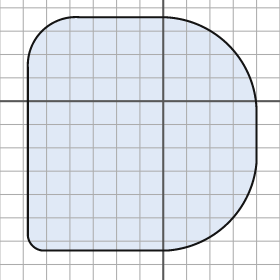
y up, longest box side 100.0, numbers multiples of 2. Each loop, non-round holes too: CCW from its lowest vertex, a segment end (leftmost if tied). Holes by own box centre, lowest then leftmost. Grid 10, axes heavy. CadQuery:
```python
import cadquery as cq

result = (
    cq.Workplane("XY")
    .moveTo(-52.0, -64.0)
    .lineTo(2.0, -64.0)
    .threePointArc((28.0, -52.0), (40.0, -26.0))
    .lineTo(40.0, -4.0)
    .threePointArc((28.0, 24.0), (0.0, 36.0))
    .lineTo(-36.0, 36.0)
    .threePointArc((-52.0, 30.0), (-58.0, 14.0))
    .lineTo(-58.0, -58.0)
    .threePointArc((-56.0, -62.0), (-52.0, -64.0))
    .close()
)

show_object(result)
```